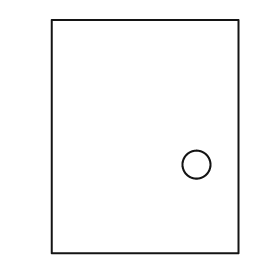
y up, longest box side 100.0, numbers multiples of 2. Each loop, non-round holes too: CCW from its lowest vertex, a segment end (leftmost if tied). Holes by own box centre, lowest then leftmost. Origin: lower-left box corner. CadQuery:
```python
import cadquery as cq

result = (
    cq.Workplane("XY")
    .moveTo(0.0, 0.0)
    .lineTo(80.0, 0.0)
    .lineTo(80.0, 100.0)
    .lineTo(0.0, 100.0)
    .close()
    .moveTo(62.0, 38.0)
    .circle(6.0)
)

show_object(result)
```